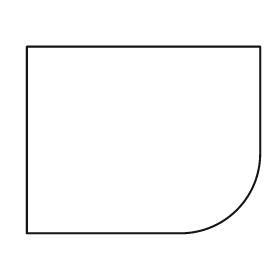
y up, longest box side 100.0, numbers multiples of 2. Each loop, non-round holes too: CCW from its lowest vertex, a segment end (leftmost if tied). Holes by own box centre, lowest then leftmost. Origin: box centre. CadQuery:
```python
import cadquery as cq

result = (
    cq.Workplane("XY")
    .moveTo(-50.0, -40.0)
    .lineTo(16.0, -40.0)
    .threePointArc((40.0, -30.0), (50.0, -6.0))
    .lineTo(50.0, 40.0)
    .lineTo(-50.0, 40.0)
    .close()
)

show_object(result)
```